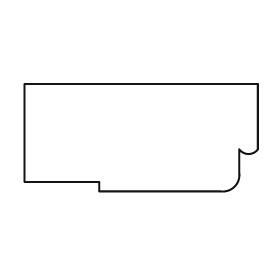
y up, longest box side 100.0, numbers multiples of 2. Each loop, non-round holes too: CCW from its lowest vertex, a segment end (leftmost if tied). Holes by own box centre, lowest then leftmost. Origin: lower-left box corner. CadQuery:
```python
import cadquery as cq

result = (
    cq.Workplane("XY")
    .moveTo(32.0, 0.0)
    .lineTo(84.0, 0.0)
    .threePointArc((90.0, 2.0), (92.0, 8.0))
    .lineTo(92.0, 18.0)
    .threePointArc((96.0, 16.0), (100.0, 18.0))
    .lineTo(100.0, 46.0)
    .lineTo(0.0, 46.0)
    .lineTo(0.0, 4.0)
    .lineTo(32.0, 4.0)
    .close()
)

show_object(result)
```